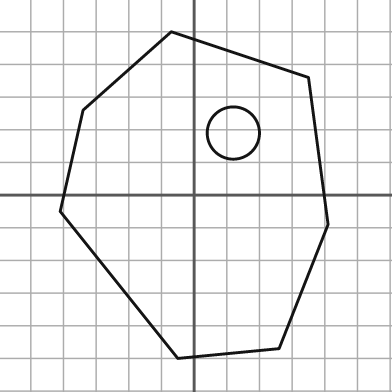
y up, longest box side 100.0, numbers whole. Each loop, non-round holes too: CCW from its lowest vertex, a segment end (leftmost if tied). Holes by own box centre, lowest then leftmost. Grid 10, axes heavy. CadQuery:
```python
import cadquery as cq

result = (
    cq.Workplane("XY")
    .moveTo(-5.0, -50.0)
    .lineTo(26.0, -47.0)
    .lineTo(41.0, -9.0)
    .lineTo(35.0, 36.0)
    .lineTo(-7.0, 50.0)
    .lineTo(-34.0, 26.0)
    .lineTo(-41.0, -5.0)
    .close()
    .moveTo(12.0, 19.0)
    .circle(8.0)
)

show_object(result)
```